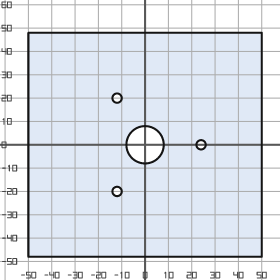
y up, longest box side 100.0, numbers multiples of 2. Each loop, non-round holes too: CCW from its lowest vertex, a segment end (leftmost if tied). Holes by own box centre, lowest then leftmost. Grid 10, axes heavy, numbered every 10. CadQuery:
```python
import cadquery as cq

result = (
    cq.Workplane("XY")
    .moveTo(-50.0, -48.0)
    .lineTo(50.0, -48.0)
    .lineTo(50.0, 48.0)
    .lineTo(-50.0, 48.0)
    .close()
    .moveTo(-12.0, -20.0)
    .circle(2.0)
    .moveTo(0.0, 0.0)
    .circle(8.0)
    .moveTo(24.0, 0.0)
    .circle(2.0)
    .moveTo(-12.0, 20.0)
    .circle(2.0)
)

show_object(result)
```